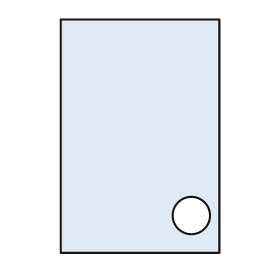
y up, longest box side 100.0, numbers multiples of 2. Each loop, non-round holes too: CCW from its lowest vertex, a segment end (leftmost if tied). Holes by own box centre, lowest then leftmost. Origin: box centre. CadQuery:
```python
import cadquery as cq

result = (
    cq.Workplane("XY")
    .moveTo(-34.0, -50.0)
    .lineTo(34.0, -50.0)
    .lineTo(34.0, 50.0)
    .lineTo(-34.0, 50.0)
    .close()
    .moveTo(22.0, -34.0)
    .circle(8.0)
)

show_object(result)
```